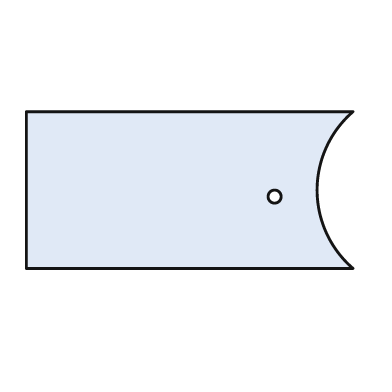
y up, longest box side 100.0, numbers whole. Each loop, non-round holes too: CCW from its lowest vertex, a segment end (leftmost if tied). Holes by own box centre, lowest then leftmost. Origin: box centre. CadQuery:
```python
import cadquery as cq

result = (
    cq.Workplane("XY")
    .moveTo(-50.0, -24.0)
    .lineTo(50.0, -24.0)
    .threePointArc((39.0, 0.0), (50.0, 24.0))
    .lineTo(-50.0, 24.0)
    .close()
    .moveTo(26.0, -2.0)
    .circle(2.0)
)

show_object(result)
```